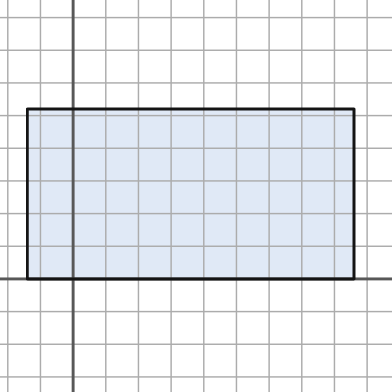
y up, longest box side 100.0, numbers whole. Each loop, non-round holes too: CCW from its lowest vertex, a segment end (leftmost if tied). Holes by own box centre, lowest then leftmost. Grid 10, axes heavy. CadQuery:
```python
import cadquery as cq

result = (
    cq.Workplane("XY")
    .moveTo(-14.0, 0.0)
    .lineTo(86.0, 0.0)
    .lineTo(86.0, 52.0)
    .lineTo(-14.0, 52.0)
    .close()
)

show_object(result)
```